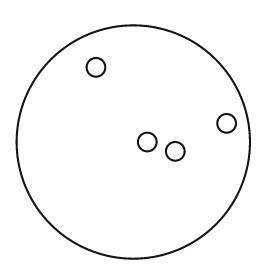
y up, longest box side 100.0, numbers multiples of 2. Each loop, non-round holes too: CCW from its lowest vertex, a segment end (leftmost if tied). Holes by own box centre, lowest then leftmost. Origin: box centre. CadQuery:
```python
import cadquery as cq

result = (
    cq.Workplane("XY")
    .moveTo(0.0, 0.0)
    .circle(50.0)
    .moveTo(18.0, -4.0)
    .circle(4.0)
    .moveTo(6.0, 0.0)
    .circle(4.0)
    .moveTo(40.0, 8.0)
    .circle(4.0)
    .moveTo(-16.0, 32.0)
    .circle(4.0)
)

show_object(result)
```